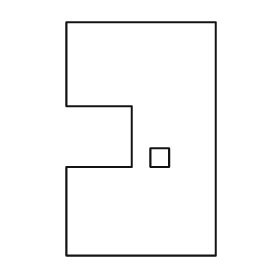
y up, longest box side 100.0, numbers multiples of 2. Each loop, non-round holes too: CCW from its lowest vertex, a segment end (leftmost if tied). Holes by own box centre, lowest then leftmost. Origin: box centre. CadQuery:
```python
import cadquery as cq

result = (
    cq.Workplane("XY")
    .moveTo(-32.0, -50.0)
    .lineTo(32.0, -50.0)
    .lineTo(32.0, 50.0)
    .lineTo(-32.0, 50.0)
    .lineTo(-32.0, 14.0)
    .lineTo(-4.0, 14.0)
    .lineTo(-4.0, -12.0)
    .lineTo(-32.0, -12.0)
    .close()
    .moveTo(4.0, -12.0)
    .lineTo(12.0, -12.0)
    .lineTo(12.0, -4.0)
    .lineTo(4.0, -4.0)
    .close()
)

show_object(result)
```